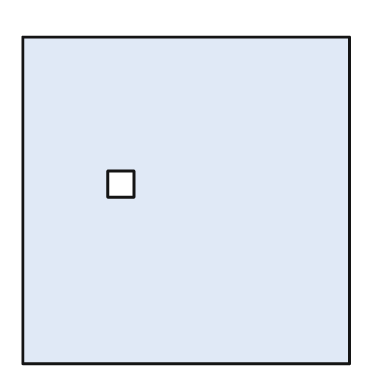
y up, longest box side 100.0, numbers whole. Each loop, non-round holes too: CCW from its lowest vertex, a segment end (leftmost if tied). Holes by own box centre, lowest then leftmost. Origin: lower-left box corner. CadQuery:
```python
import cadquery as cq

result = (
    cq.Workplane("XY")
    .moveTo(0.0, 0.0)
    .lineTo(100.0, 0.0)
    .lineTo(100.0, 100.0)
    .lineTo(0.0, 100.0)
    .close()
    .moveTo(26.0, 51.0)
    .lineTo(34.0, 51.0)
    .lineTo(34.0, 59.0)
    .lineTo(26.0, 59.0)
    .close()
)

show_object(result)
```